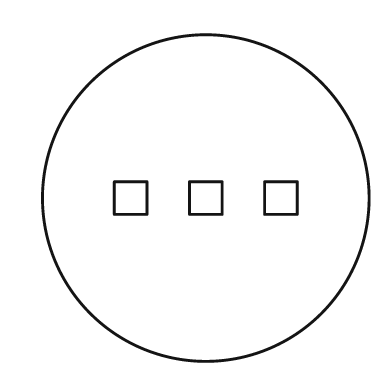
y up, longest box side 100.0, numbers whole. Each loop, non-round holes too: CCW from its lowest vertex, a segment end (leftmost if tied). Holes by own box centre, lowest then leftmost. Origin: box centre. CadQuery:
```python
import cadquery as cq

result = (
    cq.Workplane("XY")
    .moveTo(0.0, 0.0)
    .circle(50.0)
    .moveTo(-28.0, -5.0)
    .lineTo(-18.0, -5.0)
    .lineTo(-18.0, 5.0)
    .lineTo(-28.0, 5.0)
    .close()
    .moveTo(-5.0, -5.0)
    .lineTo(5.0, -5.0)
    .lineTo(5.0, 5.0)
    .lineTo(-5.0, 5.0)
    .close()
    .moveTo(18.0, -5.0)
    .lineTo(28.0, -5.0)
    .lineTo(28.0, 5.0)
    .lineTo(18.0, 5.0)
    .close()
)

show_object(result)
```